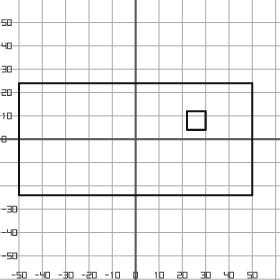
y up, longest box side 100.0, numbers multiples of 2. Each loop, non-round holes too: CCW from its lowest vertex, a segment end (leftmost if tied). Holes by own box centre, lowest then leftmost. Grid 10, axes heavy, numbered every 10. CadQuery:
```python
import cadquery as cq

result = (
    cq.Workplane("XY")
    .moveTo(-50.0, -24.0)
    .lineTo(50.0, -24.0)
    .lineTo(50.0, 24.0)
    .lineTo(-50.0, 24.0)
    .close()
    .moveTo(22.0, 4.0)
    .lineTo(30.0, 4.0)
    .lineTo(30.0, 12.0)
    .lineTo(22.0, 12.0)
    .close()
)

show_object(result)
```